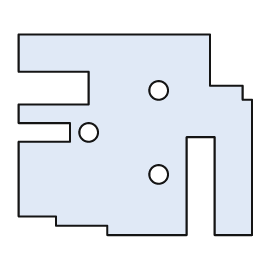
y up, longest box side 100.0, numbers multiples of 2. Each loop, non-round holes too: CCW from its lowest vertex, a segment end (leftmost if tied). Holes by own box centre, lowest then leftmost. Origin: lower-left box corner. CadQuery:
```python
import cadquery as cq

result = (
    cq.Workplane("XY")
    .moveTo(38.0, 0.0)
    .lineTo(72.0, 0.0)
    .lineTo(72.0, 42.0)
    .lineTo(84.0, 42.0)
    .lineTo(84.0, 0.0)
    .lineTo(100.0, 0.0)
    .lineTo(100.0, 58.0)
    .lineTo(96.0, 58.0)
    .lineTo(96.0, 64.0)
    .lineTo(82.0, 64.0)
    .lineTo(82.0, 86.0)
    .lineTo(0.0, 86.0)
    .lineTo(0.0, 70.0)
    .lineTo(30.0, 70.0)
    .lineTo(30.0, 56.0)
    .lineTo(0.0, 56.0)
    .lineTo(0.0, 48.0)
    .lineTo(22.0, 48.0)
    .lineTo(22.0, 40.0)
    .lineTo(0.0, 40.0)
    .lineTo(0.0, 8.0)
    .lineTo(16.0, 8.0)
    .lineTo(16.0, 4.0)
    .lineTo(38.0, 4.0)
    .close()
    .moveTo(60.0, 26.0)
    .circle(4.0)
    .moveTo(30.0, 44.0)
    .circle(4.0)
    .moveTo(60.0, 62.0)
    .circle(4.0)
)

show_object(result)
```